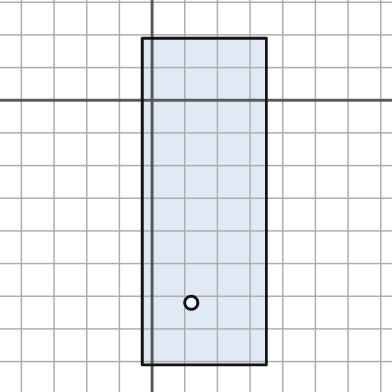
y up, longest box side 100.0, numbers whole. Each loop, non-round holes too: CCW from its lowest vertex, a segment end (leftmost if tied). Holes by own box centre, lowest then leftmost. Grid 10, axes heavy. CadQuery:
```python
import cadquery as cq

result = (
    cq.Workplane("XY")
    .moveTo(-3.0, -81.0)
    .lineTo(35.0, -81.0)
    .lineTo(35.0, 19.0)
    .lineTo(-3.0, 19.0)
    .close()
    .moveTo(12.0, -62.0)
    .circle(2.0)
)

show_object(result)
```